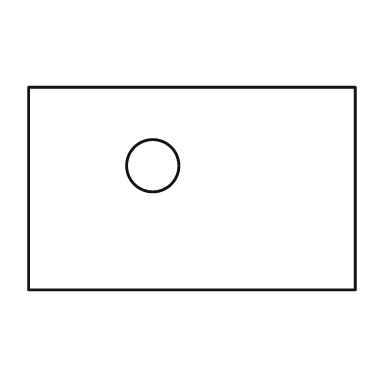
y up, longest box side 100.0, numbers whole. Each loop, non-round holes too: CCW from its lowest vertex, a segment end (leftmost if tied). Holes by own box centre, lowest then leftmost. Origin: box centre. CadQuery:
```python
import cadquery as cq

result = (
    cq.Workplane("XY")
    .moveTo(-50.0, -31.0)
    .lineTo(50.0, -31.0)
    .lineTo(50.0, 31.0)
    .lineTo(-50.0, 31.0)
    .close()
    .moveTo(-12.0, 7.0)
    .circle(8.0)
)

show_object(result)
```